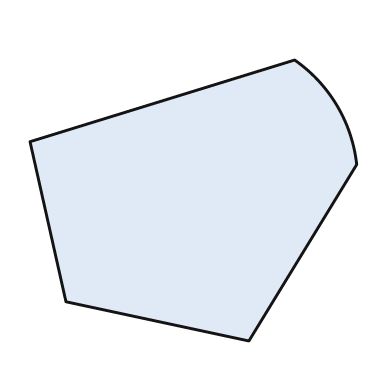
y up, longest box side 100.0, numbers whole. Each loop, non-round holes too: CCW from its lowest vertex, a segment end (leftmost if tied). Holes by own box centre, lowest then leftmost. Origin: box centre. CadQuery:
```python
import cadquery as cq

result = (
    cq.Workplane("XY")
    .moveTo(17.0, -43.0)
    .lineTo(50.0, 11.0)
    .threePointArc((44.0, 29.0), (31.0, 43.0))
    .lineTo(-50.0, 18.0)
    .lineTo(-39.0, -31.0)
    .close()
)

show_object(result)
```